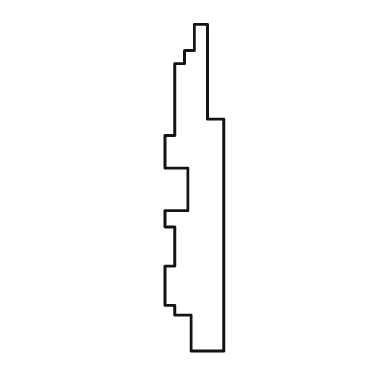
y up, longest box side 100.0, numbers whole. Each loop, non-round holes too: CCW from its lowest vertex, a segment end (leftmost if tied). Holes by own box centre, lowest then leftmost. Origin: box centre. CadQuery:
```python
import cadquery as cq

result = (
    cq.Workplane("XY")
    .moveTo(-1.0, -50.0)
    .lineTo(9.0, -50.0)
    .lineTo(9.0, 21.0)
    .lineTo(4.0, 21.0)
    .lineTo(4.0, 50.0)
    .lineTo(0.0, 50.0)
    .lineTo(0.0, 42.0)
    .lineTo(-3.0, 42.0)
    .lineTo(-3.0, 38.0)
    .lineTo(-6.0, 38.0)
    .lineTo(-6.0, 16.0)
    .lineTo(-9.0, 16.0)
    .lineTo(-9.0, 6.0)
    .lineTo(-2.0, 6.0)
    .lineTo(-2.0, -7.0)
    .lineTo(-9.0, -7.0)
    .lineTo(-9.0, -12.0)
    .lineTo(-6.0, -12.0)
    .lineTo(-6.0, -24.0)
    .lineTo(-9.0, -24.0)
    .lineTo(-9.0, -36.0)
    .lineTo(-6.0, -36.0)
    .lineTo(-6.0, -39.0)
    .lineTo(-1.0, -39.0)
    .close()
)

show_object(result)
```